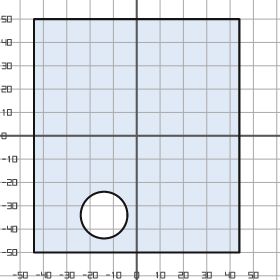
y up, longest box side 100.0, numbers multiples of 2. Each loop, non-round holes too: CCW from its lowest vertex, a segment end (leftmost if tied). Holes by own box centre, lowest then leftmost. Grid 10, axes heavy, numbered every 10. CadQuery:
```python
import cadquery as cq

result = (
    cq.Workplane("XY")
    .moveTo(-44.0, -50.0)
    .lineTo(44.0, -50.0)
    .lineTo(44.0, 50.0)
    .lineTo(-44.0, 50.0)
    .close()
    .moveTo(-14.0, -34.0)
    .circle(10.0)
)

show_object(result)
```